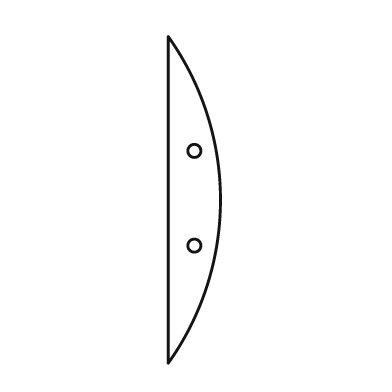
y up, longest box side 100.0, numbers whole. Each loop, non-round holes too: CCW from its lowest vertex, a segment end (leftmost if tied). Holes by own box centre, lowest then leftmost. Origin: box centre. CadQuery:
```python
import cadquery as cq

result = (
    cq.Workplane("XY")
    .moveTo(-8.0, -50.0)
    .threePointArc((8.0, 0.0), (-8.0, 50.0))
    .close()
    .moveTo(0.0, -14.0)
    .circle(2.0)
    .moveTo(0.0, 15.0)
    .circle(2.0)
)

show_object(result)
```